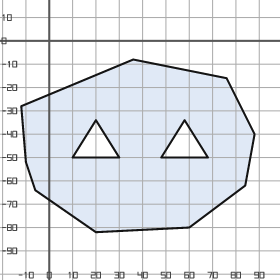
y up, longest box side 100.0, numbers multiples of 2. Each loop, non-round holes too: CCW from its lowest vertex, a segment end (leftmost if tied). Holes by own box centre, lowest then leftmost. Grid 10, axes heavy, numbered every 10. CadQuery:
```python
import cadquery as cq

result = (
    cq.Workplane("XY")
    .moveTo(20.0, -82.0)
    .lineTo(60.0, -80.0)
    .lineTo(84.0, -62.0)
    .lineTo(88.0, -40.0)
    .lineTo(76.0, -16.0)
    .lineTo(36.0, -8.0)
    .lineTo(-12.0, -28.0)
    .lineTo(-10.0, -52.0)
    .lineTo(-6.0, -64.0)
    .close()
    .moveTo(10.0, -50.0)
    .lineTo(30.0, -50.0)
    .lineTo(20.0, -34.0)
    .close()
    .moveTo(48.0, -50.0)
    .lineTo(68.0, -50.0)
    .lineTo(58.0, -34.0)
    .close()
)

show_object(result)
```